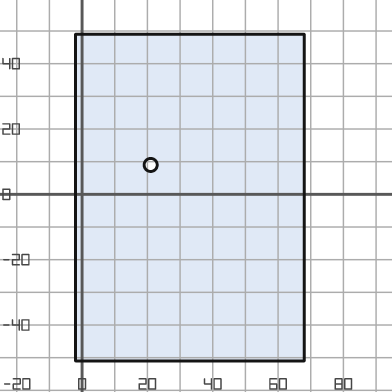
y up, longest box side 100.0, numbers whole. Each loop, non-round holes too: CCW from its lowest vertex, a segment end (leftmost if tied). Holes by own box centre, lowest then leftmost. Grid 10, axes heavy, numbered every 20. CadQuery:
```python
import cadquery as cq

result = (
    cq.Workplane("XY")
    .moveTo(-2.0, -51.0)
    .lineTo(68.0, -51.0)
    .lineTo(68.0, 49.0)
    .lineTo(-2.0, 49.0)
    .close()
    .moveTo(21.0, 9.0)
    .circle(2.0)
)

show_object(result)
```